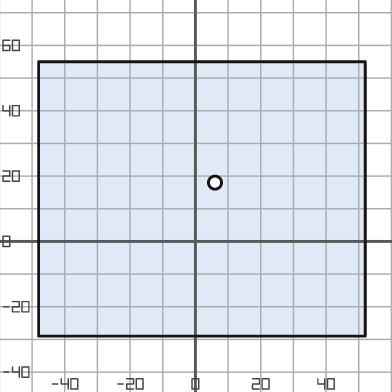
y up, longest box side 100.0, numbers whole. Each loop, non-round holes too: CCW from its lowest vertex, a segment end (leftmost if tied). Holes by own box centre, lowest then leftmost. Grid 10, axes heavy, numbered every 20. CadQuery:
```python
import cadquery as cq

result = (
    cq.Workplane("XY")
    .moveTo(-48.0, -29.0)
    .lineTo(52.0, -29.0)
    .lineTo(52.0, 55.0)
    .lineTo(-48.0, 55.0)
    .close()
    .moveTo(6.0, 18.0)
    .circle(2.0)
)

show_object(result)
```